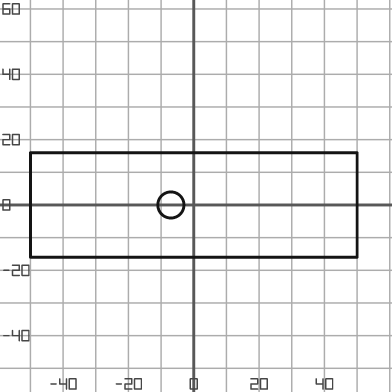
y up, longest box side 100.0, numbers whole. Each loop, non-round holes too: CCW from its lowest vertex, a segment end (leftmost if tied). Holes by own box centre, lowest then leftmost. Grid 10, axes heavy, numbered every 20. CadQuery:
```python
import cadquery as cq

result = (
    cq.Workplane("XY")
    .moveTo(-50.0, -16.0)
    .lineTo(50.0, -16.0)
    .lineTo(50.0, 16.0)
    .lineTo(-50.0, 16.0)
    .close()
    .moveTo(-7.0, 0.0)
    .circle(4.0)
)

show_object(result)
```